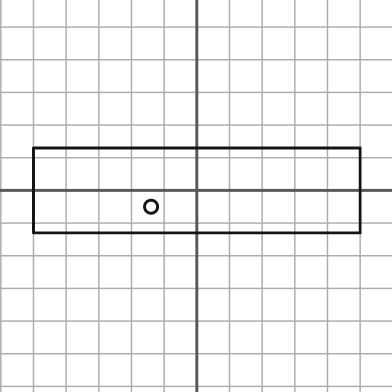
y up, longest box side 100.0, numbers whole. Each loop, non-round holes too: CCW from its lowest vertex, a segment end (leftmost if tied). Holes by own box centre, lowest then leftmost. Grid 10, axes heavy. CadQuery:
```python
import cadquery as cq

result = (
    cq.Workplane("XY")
    .moveTo(-50.0, -13.0)
    .lineTo(50.0, -13.0)
    .lineTo(50.0, 13.0)
    .lineTo(-50.0, 13.0)
    .close()
    .moveTo(-14.0, -5.0)
    .circle(2.0)
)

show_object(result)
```